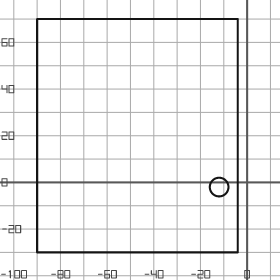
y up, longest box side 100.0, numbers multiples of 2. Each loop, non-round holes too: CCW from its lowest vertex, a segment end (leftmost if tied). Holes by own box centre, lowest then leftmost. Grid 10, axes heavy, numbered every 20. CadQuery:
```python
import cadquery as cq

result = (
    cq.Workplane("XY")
    .moveTo(-90.0, -30.0)
    .lineTo(-4.0, -30.0)
    .lineTo(-4.0, 70.0)
    .lineTo(-90.0, 70.0)
    .close()
    .moveTo(-12.0, -2.0)
    .circle(4.0)
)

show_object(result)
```